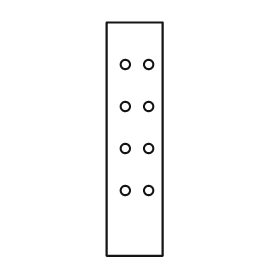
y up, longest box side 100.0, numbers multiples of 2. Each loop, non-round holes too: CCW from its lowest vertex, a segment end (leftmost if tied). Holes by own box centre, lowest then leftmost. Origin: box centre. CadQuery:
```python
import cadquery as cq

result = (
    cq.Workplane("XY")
    .moveTo(-12.0, -50.0)
    .lineTo(12.0, -50.0)
    .lineTo(12.0, 50.0)
    .lineTo(-12.0, 50.0)
    .close()
    .moveTo(-4.0, -22.0)
    .circle(2.0)
    .moveTo(6.0, -22.0)
    .circle(2.0)
    .moveTo(-4.0, -4.0)
    .circle(2.0)
    .moveTo(6.0, -4.0)
    .circle(2.0)
    .moveTo(-4.0, 14.0)
    .circle(2.0)
    .moveTo(6.0, 14.0)
    .circle(2.0)
    .moveTo(-4.0, 32.0)
    .circle(2.0)
    .moveTo(6.0, 32.0)
    .circle(2.0)
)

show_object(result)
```